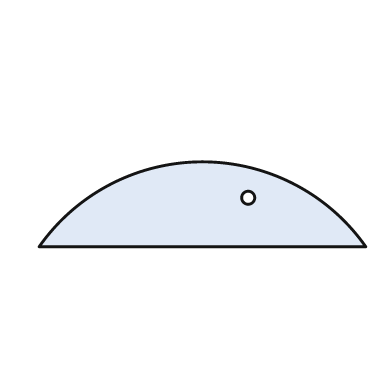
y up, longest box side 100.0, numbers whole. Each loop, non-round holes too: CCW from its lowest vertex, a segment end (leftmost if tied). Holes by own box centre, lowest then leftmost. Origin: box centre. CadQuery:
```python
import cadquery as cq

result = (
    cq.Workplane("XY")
    .moveTo(-50.0, -13.0)
    .lineTo(50.0, -13.0)
    .threePointArc((0.0, 13.0), (-50.0, -13.0))
    .close()
    .moveTo(14.0, 2.0)
    .circle(2.0)
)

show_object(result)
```